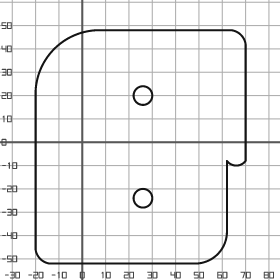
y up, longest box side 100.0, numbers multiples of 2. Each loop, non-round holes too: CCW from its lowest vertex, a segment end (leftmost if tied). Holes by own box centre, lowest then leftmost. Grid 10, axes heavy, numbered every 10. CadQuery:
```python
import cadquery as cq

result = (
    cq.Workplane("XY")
    .moveTo(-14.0, -52.0)
    .lineTo(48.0, -52.0)
    .threePointArc((58.0, -48.0), (62.0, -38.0))
    .lineTo(62.0, -8.0)
    .threePointArc((66.0, -10.0), (70.0, -8.0))
    .lineTo(70.0, 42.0)
    .threePointArc((68.0, 46.0), (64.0, 48.0))
    .lineTo(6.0, 48.0)
    .threePointArc((-12.0, 40.0), (-20.0, 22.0))
    .lineTo(-20.0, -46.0)
    .threePointArc((-18.0, -50.0), (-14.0, -52.0))
    .close()
    .moveTo(26.0, -24.0)
    .circle(4.0)
    .moveTo(26.0, 20.0)
    .circle(4.0)
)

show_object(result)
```